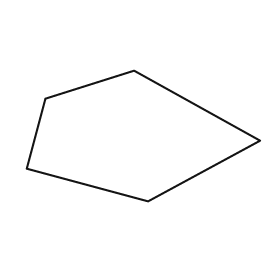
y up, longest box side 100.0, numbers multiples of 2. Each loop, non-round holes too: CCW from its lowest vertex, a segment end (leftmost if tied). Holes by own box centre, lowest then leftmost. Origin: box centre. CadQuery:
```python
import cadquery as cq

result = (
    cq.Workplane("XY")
    .moveTo(2.0, -28.0)
    .lineTo(50.0, -2.0)
    .lineTo(-4.0, 28.0)
    .lineTo(-42.0, 16.0)
    .lineTo(-50.0, -14.0)
    .close()
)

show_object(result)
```